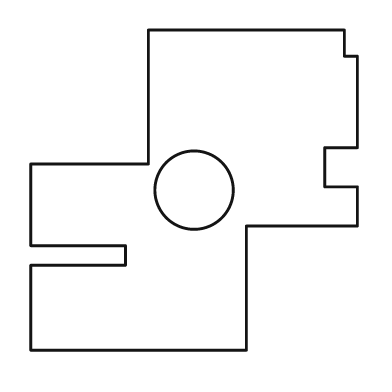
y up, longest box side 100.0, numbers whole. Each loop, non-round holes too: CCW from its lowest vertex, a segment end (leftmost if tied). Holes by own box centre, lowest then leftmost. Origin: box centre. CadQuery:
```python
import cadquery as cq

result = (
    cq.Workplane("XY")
    .moveTo(-50.0, -49.0)
    .lineTo(16.0, -49.0)
    .lineTo(16.0, -11.0)
    .lineTo(50.0, -11.0)
    .lineTo(50.0, 1.0)
    .lineTo(40.0, 1.0)
    .lineTo(40.0, 13.0)
    .lineTo(50.0, 13.0)
    .lineTo(50.0, 41.0)
    .lineTo(46.0, 41.0)
    .lineTo(46.0, 49.0)
    .lineTo(-14.0, 49.0)
    .lineTo(-14.0, 8.0)
    .lineTo(-50.0, 8.0)
    .lineTo(-50.0, -17.0)
    .lineTo(-21.0, -17.0)
    .lineTo(-21.0, -23.0)
    .lineTo(-50.0, -23.0)
    .close()
    .moveTo(0.0, 0.0)
    .circle(12.0)
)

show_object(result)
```